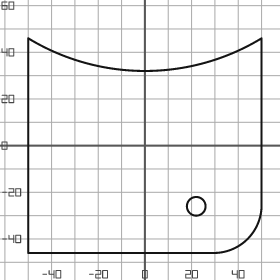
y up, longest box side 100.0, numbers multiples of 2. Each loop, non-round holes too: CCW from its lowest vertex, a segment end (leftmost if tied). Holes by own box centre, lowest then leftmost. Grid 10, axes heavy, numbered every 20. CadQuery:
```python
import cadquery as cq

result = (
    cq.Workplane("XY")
    .moveTo(-50.0, -46.0)
    .lineTo(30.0, -46.0)
    .threePointArc((44.0, -40.0), (50.0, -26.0))
    .lineTo(50.0, 46.0)
    .threePointArc((0.0, 32.0), (-50.0, 46.0))
    .close()
    .moveTo(22.0, -26.0)
    .circle(4.0)
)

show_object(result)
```